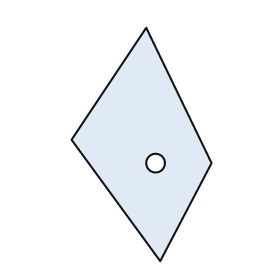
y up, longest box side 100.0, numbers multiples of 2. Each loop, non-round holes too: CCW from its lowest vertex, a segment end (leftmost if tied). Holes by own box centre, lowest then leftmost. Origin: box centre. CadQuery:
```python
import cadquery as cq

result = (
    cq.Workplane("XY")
    .moveTo(8.0, -50.0)
    .lineTo(30.0, -8.0)
    .lineTo(2.0, 50.0)
    .lineTo(-30.0, 2.0)
    .close()
    .moveTo(6.0, -8.0)
    .circle(4.0)
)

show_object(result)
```